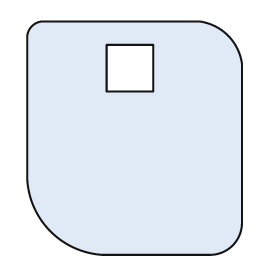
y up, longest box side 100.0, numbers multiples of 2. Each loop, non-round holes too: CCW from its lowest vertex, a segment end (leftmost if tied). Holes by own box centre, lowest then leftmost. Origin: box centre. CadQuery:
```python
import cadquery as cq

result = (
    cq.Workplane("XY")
    .moveTo(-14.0, -50.0)
    .lineTo(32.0, -50.0)
    .threePointArc((42.0, -46.0), (46.0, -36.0))
    .lineTo(46.0, 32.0)
    .threePointArc((40.0, 44.0), (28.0, 50.0))
    .lineTo(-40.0, 50.0)
    .threePointArc((-44.0, 48.0), (-46.0, 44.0))
    .lineTo(-46.0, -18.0)
    .threePointArc((-36.0, -40.0), (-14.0, -50.0))
    .close()
    .moveTo(-12.0, 20.0)
    .lineTo(8.0, 20.0)
    .lineTo(8.0, 40.0)
    .lineTo(-12.0, 40.0)
    .close()
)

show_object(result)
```